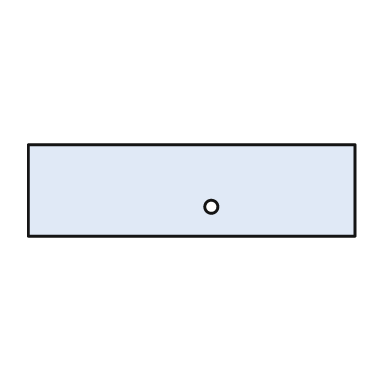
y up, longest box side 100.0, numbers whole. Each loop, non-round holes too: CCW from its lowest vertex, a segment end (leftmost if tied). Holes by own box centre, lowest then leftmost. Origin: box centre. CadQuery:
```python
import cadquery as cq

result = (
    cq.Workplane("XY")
    .moveTo(-50.0, -14.0)
    .lineTo(50.0, -14.0)
    .lineTo(50.0, 14.0)
    .lineTo(-50.0, 14.0)
    .close()
    .moveTo(6.0, -5.0)
    .circle(2.0)
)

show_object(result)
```